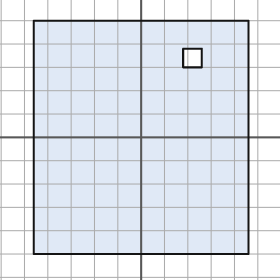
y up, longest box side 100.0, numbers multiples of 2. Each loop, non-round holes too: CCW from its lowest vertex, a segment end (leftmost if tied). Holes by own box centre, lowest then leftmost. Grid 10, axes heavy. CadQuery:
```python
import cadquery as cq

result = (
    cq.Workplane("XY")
    .moveTo(-46.0, -50.0)
    .lineTo(46.0, -50.0)
    .lineTo(46.0, 50.0)
    .lineTo(-46.0, 50.0)
    .close()
    .moveTo(18.0, 30.0)
    .lineTo(26.0, 30.0)
    .lineTo(26.0, 38.0)
    .lineTo(18.0, 38.0)
    .close()
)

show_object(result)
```